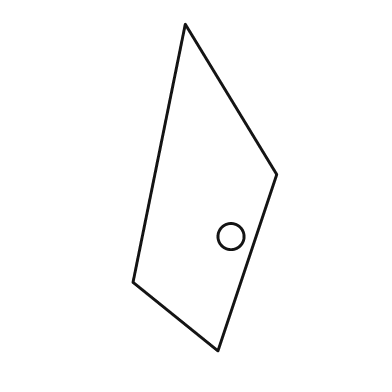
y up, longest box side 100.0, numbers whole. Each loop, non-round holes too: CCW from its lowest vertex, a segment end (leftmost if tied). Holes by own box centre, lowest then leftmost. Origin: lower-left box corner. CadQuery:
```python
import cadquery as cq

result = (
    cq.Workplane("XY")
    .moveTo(26.0, 0.0)
    .lineTo(44.0, 54.0)
    .lineTo(16.0, 100.0)
    .lineTo(0.0, 21.0)
    .close()
    .moveTo(30.0, 35.0)
    .circle(4.0)
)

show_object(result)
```